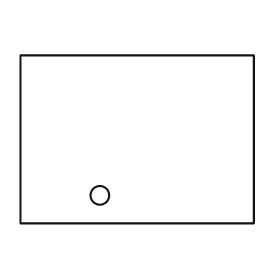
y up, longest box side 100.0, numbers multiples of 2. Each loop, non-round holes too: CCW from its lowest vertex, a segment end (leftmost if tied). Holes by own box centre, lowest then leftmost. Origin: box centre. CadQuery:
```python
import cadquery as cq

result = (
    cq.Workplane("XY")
    .moveTo(-50.0, -36.0)
    .lineTo(50.0, -36.0)
    .lineTo(50.0, 36.0)
    .lineTo(-50.0, 36.0)
    .close()
    .moveTo(-16.0, -24.0)
    .circle(4.0)
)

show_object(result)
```